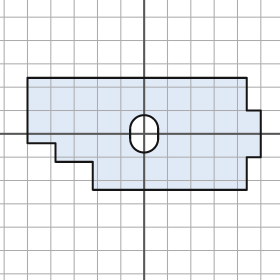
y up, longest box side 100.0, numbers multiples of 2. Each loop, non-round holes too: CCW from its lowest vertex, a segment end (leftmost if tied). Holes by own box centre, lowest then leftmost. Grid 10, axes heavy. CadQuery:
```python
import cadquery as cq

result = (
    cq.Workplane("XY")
    .moveTo(-22.0, -24.0)
    .lineTo(44.0, -24.0)
    .lineTo(44.0, -10.0)
    .lineTo(50.0, -10.0)
    .lineTo(50.0, 10.0)
    .lineTo(44.0, 10.0)
    .lineTo(44.0, 24.0)
    .lineTo(-50.0, 24.0)
    .lineTo(-50.0, -4.0)
    .lineTo(-38.0, -4.0)
    .lineTo(-38.0, -12.0)
    .lineTo(-22.0, -12.0)
    .close()
    .moveTo(-6.0, -2.0)
    .threePointArc((0.0, -8.0), (6.0, -2.0))
    .lineTo(6.0, 2.0)
    .threePointArc((0.0, 8.0), (-6.0, 2.0))
    .close()
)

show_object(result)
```